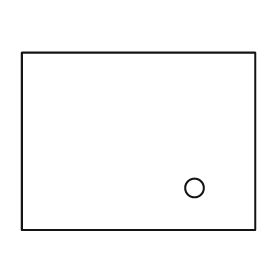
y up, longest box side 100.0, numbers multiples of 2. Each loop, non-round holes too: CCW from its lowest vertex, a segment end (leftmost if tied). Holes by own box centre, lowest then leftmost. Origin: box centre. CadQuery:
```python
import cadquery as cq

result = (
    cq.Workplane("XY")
    .moveTo(-50.0, -38.0)
    .lineTo(50.0, -38.0)
    .lineTo(50.0, 38.0)
    .lineTo(-50.0, 38.0)
    .close()
    .moveTo(24.0, -20.0)
    .circle(4.0)
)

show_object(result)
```